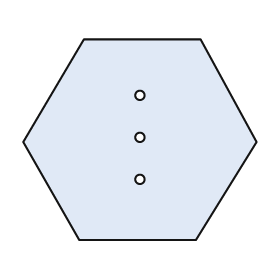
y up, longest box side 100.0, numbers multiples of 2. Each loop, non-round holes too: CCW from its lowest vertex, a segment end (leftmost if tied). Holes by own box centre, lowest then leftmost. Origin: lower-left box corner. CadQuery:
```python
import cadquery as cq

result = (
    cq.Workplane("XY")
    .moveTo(24.0, 0.0)
    .lineTo(74.0, 0.0)
    .lineTo(100.0, 42.0)
    .lineTo(76.0, 86.0)
    .lineTo(26.0, 86.0)
    .lineTo(0.0, 42.0)
    .close()
    .moveTo(50.0, 26.0)
    .circle(2.0)
    .moveTo(50.0, 44.0)
    .circle(2.0)
    .moveTo(50.0, 62.0)
    .circle(2.0)
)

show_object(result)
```